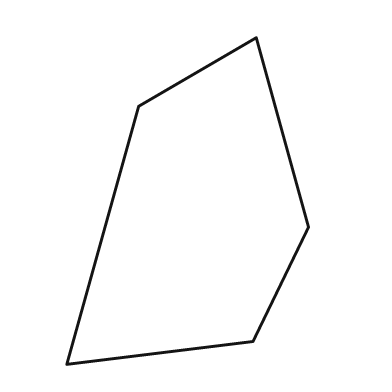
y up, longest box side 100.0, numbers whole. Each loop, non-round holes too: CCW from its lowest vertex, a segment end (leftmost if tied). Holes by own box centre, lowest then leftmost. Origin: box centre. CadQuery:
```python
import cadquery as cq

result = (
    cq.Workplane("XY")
    .moveTo(-37.0, -50.0)
    .lineTo(20.0, -43.0)
    .lineTo(37.0, -8.0)
    .lineTo(21.0, 50.0)
    .lineTo(-15.0, 29.0)
    .close()
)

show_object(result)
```